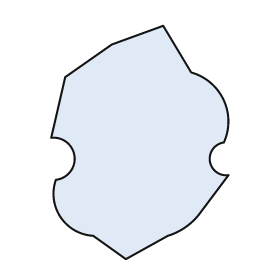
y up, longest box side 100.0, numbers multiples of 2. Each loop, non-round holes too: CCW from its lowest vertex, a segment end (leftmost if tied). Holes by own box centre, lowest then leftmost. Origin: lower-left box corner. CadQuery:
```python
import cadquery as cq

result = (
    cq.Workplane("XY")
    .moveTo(32.0, 0.0)
    .lineTo(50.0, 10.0)
    .threePointArc((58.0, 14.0), (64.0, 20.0))
    .lineTo(76.0, 36.0)
    .threePointArc((68.0, 42.0), (74.0, 50.0))
    .threePointArc((74.0, 68.0), (60.0, 80.0))
    .lineTo(48.0, 100.0)
    .lineTo(26.0, 92.0)
    .lineTo(6.0, 78.0)
    .lineTo(0.0, 52.0)
    .threePointArc((10.0, 44.0), (2.0, 34.0))
    .threePointArc((4.0, 18.0), (18.0, 10.0))
    .close()
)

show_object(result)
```